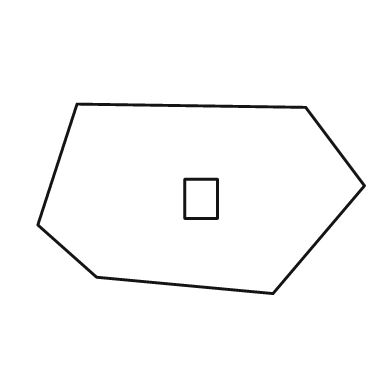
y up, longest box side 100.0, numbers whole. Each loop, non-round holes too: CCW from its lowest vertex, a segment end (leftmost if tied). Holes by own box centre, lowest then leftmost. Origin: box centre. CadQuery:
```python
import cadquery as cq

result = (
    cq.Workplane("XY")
    .moveTo(22.0, -29.0)
    .lineTo(50.0, 4.0)
    .lineTo(32.0, 28.0)
    .lineTo(-38.0, 29.0)
    .lineTo(-50.0, -8.0)
    .lineTo(-32.0, -24.0)
    .close()
    .moveTo(-5.0, -6.0)
    .lineTo(5.0, -6.0)
    .lineTo(5.0, 6.0)
    .lineTo(-5.0, 6.0)
    .close()
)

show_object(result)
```